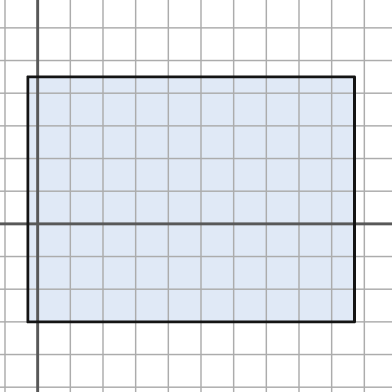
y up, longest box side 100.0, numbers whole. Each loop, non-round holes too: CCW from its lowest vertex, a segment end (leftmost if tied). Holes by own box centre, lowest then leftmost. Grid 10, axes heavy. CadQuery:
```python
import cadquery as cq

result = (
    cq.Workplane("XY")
    .moveTo(-3.0, -30.0)
    .lineTo(97.0, -30.0)
    .lineTo(97.0, 45.0)
    .lineTo(-3.0, 45.0)
    .close()
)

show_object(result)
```